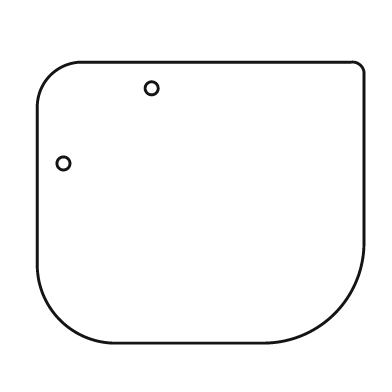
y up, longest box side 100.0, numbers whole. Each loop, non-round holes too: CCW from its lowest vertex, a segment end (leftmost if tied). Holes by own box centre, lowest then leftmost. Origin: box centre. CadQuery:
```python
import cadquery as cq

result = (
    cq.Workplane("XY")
    .moveTo(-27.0, -43.0)
    .lineTo(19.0, -43.0)
    .threePointArc((41.0, -34.0), (50.0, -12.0))
    .lineTo(50.0, 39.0)
    .threePointArc((49.0, 42.0), (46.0, 43.0))
    .lineTo(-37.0, 43.0)
    .threePointArc((-46.0, 39.0), (-50.0, 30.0))
    .lineTo(-50.0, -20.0)
    .threePointArc((-43.0, -36.0), (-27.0, -43.0))
    .close()
    .moveTo(-42.0, 12.0)
    .circle(2.0)
    .moveTo(-15.0, 35.0)
    .circle(2.0)
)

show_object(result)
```